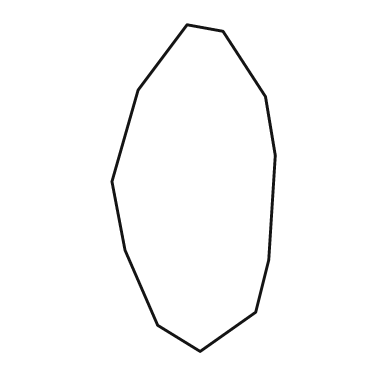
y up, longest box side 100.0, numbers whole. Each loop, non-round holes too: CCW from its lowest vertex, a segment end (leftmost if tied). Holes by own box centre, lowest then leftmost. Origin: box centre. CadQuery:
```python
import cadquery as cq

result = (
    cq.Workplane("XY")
    .moveTo(2.0, -50.0)
    .lineTo(19.0, -38.0)
    .lineTo(23.0, -22.0)
    .lineTo(25.0, 10.0)
    .lineTo(22.0, 28.0)
    .lineTo(9.0, 48.0)
    .lineTo(-2.0, 50.0)
    .lineTo(-17.0, 30.0)
    .lineTo(-25.0, 2.0)
    .lineTo(-21.0, -19.0)
    .lineTo(-11.0, -42.0)
    .close()
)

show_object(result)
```